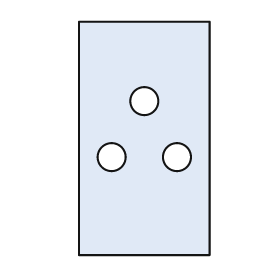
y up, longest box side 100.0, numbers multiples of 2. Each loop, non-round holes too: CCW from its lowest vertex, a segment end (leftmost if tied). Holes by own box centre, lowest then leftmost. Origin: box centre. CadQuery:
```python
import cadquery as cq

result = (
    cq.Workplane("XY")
    .moveTo(-28.0, -50.0)
    .lineTo(28.0, -50.0)
    .lineTo(28.0, 50.0)
    .lineTo(-28.0, 50.0)
    .close()
    .moveTo(-14.0, -8.0)
    .circle(6.0)
    .moveTo(14.0, -8.0)
    .circle(6.0)
    .moveTo(0.0, 16.0)
    .circle(6.0)
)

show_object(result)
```